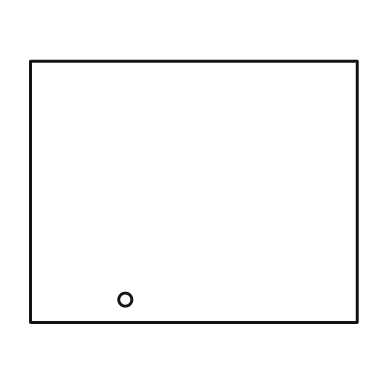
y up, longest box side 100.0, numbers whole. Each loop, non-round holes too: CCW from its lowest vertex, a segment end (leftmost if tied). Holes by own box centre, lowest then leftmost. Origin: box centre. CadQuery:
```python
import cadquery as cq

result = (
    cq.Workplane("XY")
    .moveTo(-50.0, -40.0)
    .lineTo(50.0, -40.0)
    .lineTo(50.0, 40.0)
    .lineTo(-50.0, 40.0)
    .close()
    .moveTo(-21.0, -33.0)
    .circle(2.0)
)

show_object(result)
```